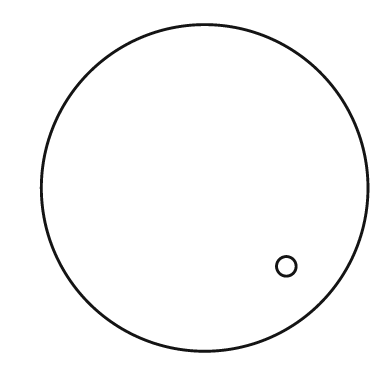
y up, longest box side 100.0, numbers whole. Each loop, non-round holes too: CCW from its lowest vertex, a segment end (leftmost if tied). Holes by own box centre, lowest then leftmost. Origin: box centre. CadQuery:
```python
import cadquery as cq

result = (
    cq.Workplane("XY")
    .moveTo(0.0, 0.0)
    .circle(50.0)
    .moveTo(25.0, -24.0)
    .circle(3.0)
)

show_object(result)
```